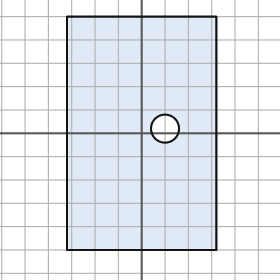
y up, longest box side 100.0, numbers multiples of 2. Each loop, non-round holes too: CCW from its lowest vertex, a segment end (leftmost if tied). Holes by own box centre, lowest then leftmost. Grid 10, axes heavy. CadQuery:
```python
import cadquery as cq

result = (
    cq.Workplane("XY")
    .moveTo(-32.0, -50.0)
    .lineTo(32.0, -50.0)
    .lineTo(32.0, 50.0)
    .lineTo(-32.0, 50.0)
    .close()
    .moveTo(10.0, 2.0)
    .circle(6.0)
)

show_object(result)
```